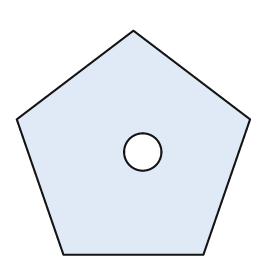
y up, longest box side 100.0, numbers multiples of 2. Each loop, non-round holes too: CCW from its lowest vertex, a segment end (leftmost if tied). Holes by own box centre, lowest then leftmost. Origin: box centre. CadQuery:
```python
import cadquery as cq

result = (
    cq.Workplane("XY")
    .moveTo(-30.0, -48.0)
    .lineTo(30.0, -48.0)
    .lineTo(50.0, 10.0)
    .lineTo(0.0, 48.0)
    .lineTo(-50.0, 10.0)
    .close()
    .moveTo(4.0, -4.0)
    .circle(8.0)
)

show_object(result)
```